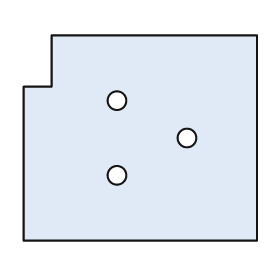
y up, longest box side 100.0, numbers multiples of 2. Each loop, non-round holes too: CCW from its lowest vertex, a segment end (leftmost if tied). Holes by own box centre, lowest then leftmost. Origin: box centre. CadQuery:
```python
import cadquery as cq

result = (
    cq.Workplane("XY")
    .moveTo(-50.0, -44.0)
    .lineTo(50.0, -44.0)
    .lineTo(50.0, 44.0)
    .lineTo(-38.0, 44.0)
    .lineTo(-38.0, 22.0)
    .lineTo(-50.0, 22.0)
    .close()
    .moveTo(-10.0, -16.0)
    .circle(4.0)
    .moveTo(20.0, 0.0)
    .circle(4.0)
    .moveTo(-10.0, 16.0)
    .circle(4.0)
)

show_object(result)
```